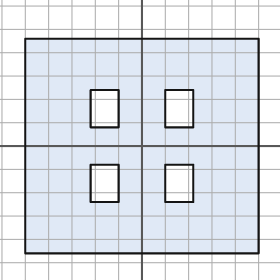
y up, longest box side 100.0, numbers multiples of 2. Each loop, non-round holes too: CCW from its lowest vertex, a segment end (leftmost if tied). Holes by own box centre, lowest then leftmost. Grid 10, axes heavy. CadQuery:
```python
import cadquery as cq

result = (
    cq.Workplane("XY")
    .moveTo(-50.0, -46.0)
    .lineTo(50.0, -46.0)
    .lineTo(50.0, 46.0)
    .lineTo(-50.0, 46.0)
    .close()
    .moveTo(-22.0, -24.0)
    .lineTo(-10.0, -24.0)
    .lineTo(-10.0, -8.0)
    .lineTo(-22.0, -8.0)
    .close()
    .moveTo(10.0, -24.0)
    .lineTo(22.0, -24.0)
    .lineTo(22.0, -8.0)
    .lineTo(10.0, -8.0)
    .close()
    .moveTo(-22.0, 8.0)
    .lineTo(-10.0, 8.0)
    .lineTo(-10.0, 24.0)
    .lineTo(-22.0, 24.0)
    .close()
    .moveTo(10.0, 8.0)
    .lineTo(22.0, 8.0)
    .lineTo(22.0, 24.0)
    .lineTo(10.0, 24.0)
    .close()
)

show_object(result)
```